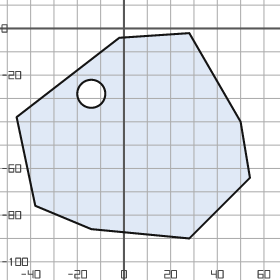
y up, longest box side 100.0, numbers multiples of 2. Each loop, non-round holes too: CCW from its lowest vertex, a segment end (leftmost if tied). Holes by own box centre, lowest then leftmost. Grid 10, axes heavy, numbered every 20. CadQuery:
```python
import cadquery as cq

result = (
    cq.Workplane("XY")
    .moveTo(28.0, -90.0)
    .lineTo(54.0, -64.0)
    .lineTo(50.0, -40.0)
    .lineTo(28.0, -2.0)
    .lineTo(-2.0, -4.0)
    .lineTo(-46.0, -38.0)
    .lineTo(-38.0, -76.0)
    .lineTo(-14.0, -86.0)
    .close()
    .moveTo(-14.0, -28.0)
    .circle(6.0)
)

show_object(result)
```